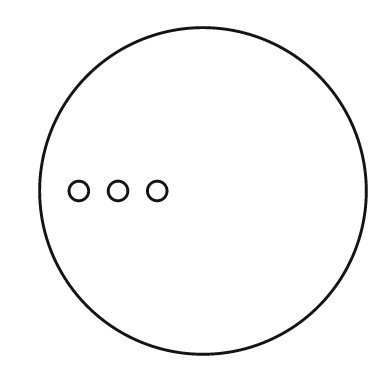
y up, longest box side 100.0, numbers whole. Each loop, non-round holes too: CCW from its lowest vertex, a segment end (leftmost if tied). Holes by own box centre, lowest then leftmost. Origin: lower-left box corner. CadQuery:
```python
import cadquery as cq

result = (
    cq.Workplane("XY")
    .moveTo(50.0, 50.0)
    .circle(50.0)
    .moveTo(12.0, 50.0)
    .circle(3.0)
    .moveTo(24.0, 50.0)
    .circle(3.0)
    .moveTo(36.0, 50.0)
    .circle(3.0)
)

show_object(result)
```